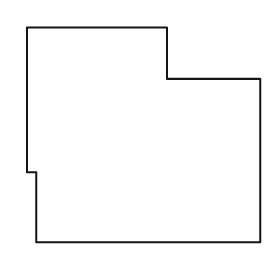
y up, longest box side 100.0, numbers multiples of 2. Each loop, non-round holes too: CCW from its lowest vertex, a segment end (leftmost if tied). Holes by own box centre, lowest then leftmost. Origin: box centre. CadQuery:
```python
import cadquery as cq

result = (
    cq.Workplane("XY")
    .moveTo(-46.0, -46.0)
    .lineTo(50.0, -46.0)
    .lineTo(50.0, 24.0)
    .lineTo(10.0, 24.0)
    .lineTo(10.0, 46.0)
    .lineTo(-50.0, 46.0)
    .lineTo(-50.0, -16.0)
    .lineTo(-46.0, -16.0)
    .close()
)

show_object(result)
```